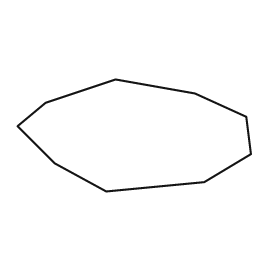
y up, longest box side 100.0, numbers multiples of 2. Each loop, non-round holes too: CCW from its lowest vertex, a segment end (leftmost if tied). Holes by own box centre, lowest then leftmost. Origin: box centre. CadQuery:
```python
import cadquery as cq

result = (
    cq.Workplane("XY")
    .moveTo(-12.0, -24.0)
    .lineTo(30.0, -20.0)
    .lineTo(50.0, -8.0)
    .lineTo(48.0, 8.0)
    .lineTo(26.0, 18.0)
    .lineTo(-8.0, 24.0)
    .lineTo(-38.0, 14.0)
    .lineTo(-50.0, 4.0)
    .lineTo(-34.0, -12.0)
    .close()
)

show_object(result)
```